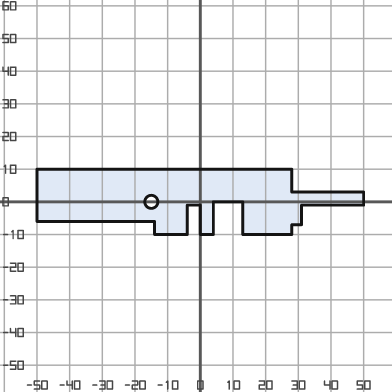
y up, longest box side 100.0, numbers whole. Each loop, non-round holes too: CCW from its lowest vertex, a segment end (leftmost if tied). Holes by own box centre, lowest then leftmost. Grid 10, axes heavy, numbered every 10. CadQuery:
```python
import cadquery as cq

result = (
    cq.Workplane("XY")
    .moveTo(-14.0, -10.0)
    .lineTo(-4.0, -10.0)
    .lineTo(-4.0, -1.0)
    .lineTo(0.0, -1.0)
    .lineTo(0.0, -10.0)
    .lineTo(4.0, -10.0)
    .lineTo(4.0, 0.0)
    .lineTo(13.0, 0.0)
    .lineTo(13.0, -10.0)
    .lineTo(28.0, -10.0)
    .lineTo(28.0, -7.0)
    .lineTo(31.0, -7.0)
    .lineTo(31.0, -1.0)
    .lineTo(50.0, -1.0)
    .lineTo(50.0, 3.0)
    .lineTo(28.0, 3.0)
    .lineTo(28.0, 10.0)
    .lineTo(-50.0, 10.0)
    .lineTo(-50.0, -6.0)
    .lineTo(-14.0, -6.0)
    .close()
    .moveTo(-15.0, 0.0)
    .circle(2.0)
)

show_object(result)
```